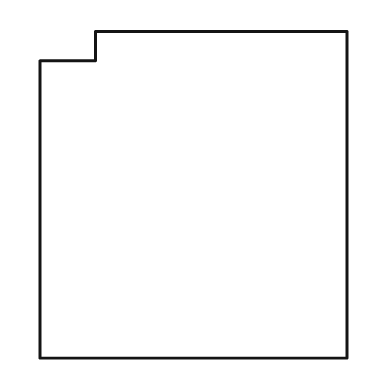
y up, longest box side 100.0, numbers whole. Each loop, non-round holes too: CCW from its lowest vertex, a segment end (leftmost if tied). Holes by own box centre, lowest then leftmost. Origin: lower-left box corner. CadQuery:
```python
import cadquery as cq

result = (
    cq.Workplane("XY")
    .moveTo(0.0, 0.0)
    .lineTo(94.0, 0.0)
    .lineTo(94.0, 100.0)
    .lineTo(17.0, 100.0)
    .lineTo(17.0, 91.0)
    .lineTo(0.0, 91.0)
    .close()
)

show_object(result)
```